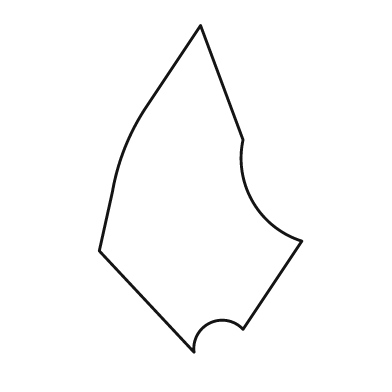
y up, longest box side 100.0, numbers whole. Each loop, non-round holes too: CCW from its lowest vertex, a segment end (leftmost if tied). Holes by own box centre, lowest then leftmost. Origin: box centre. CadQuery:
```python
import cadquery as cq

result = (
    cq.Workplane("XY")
    .moveTo(-2.0, -50.0)
    .threePointArc((3.0, -41.0), (13.0, -43.0))
    .lineTo(31.0, -16.0)
    .threePointArc((16.0, -4.0), (13.0, 15.0))
    .lineTo(0.0, 50.0)
    .lineTo(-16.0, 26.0)
    .threePointArc((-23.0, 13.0), (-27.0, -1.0))
    .lineTo(-31.0, -19.0)
    .close()
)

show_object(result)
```